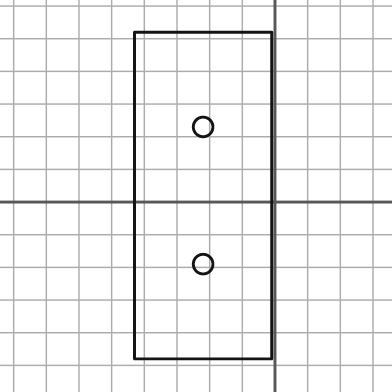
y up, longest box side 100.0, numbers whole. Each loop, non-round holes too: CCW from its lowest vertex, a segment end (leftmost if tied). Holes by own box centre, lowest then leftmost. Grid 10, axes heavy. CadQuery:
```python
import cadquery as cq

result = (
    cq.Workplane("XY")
    .moveTo(-43.0, -48.0)
    .lineTo(-1.0, -48.0)
    .lineTo(-1.0, 52.0)
    .lineTo(-43.0, 52.0)
    .close()
    .moveTo(-22.0, -19.0)
    .circle(3.0)
    .moveTo(-22.0, 23.0)
    .circle(3.0)
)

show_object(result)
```